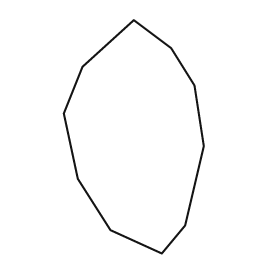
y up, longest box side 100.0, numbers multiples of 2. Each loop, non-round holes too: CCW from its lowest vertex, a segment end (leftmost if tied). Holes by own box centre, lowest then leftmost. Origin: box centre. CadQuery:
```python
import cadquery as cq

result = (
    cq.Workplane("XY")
    .moveTo(12.0, -50.0)
    .lineTo(22.0, -38.0)
    .lineTo(30.0, -4.0)
    .lineTo(26.0, 22.0)
    .lineTo(16.0, 38.0)
    .lineTo(0.0, 50.0)
    .lineTo(-22.0, 30.0)
    .lineTo(-30.0, 10.0)
    .lineTo(-24.0, -18.0)
    .lineTo(-10.0, -40.0)
    .close()
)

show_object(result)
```